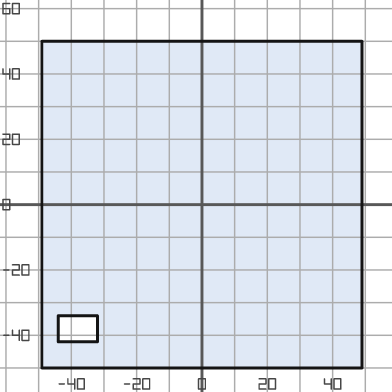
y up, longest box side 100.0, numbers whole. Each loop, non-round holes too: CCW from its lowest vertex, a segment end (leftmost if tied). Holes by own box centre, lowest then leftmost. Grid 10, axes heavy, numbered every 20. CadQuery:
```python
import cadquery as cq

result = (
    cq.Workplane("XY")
    .moveTo(-49.0, -50.0)
    .lineTo(49.0, -50.0)
    .lineTo(49.0, 50.0)
    .lineTo(-49.0, 50.0)
    .close()
    .moveTo(-44.0, -42.0)
    .lineTo(-32.0, -42.0)
    .lineTo(-32.0, -34.0)
    .lineTo(-44.0, -34.0)
    .close()
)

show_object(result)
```